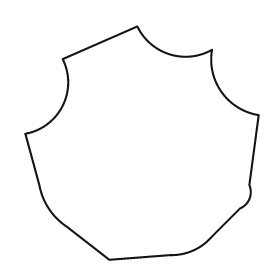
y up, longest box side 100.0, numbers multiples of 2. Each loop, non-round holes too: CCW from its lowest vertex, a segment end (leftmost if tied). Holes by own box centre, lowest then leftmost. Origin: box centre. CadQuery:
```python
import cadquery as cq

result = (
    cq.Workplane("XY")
    .moveTo(-14.0, -50.0)
    .lineTo(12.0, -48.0)
    .threePointArc((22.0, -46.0), (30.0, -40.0))
    .lineTo(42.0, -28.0)
    .threePointArc((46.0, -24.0), (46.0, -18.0))
    .lineTo(50.0, 12.0)
    .threePointArc((34.0, 22.0), (30.0, 40.0))
    .threePointArc((12.0, 38.0), (-2.0, 50.0))
    .lineTo(-34.0, 36.0)
    .threePointArc((-34.0, 16.0), (-50.0, 4.0))
    .lineTo(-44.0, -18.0)
    .threePointArc((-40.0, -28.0), (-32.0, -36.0))
    .close()
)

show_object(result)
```